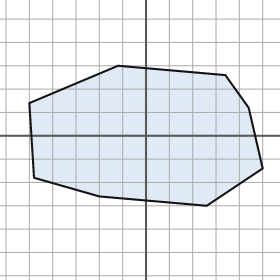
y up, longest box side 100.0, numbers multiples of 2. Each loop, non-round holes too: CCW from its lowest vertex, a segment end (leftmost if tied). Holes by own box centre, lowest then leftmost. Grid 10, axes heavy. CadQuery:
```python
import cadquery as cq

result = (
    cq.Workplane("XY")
    .moveTo(26.0, -30.0)
    .lineTo(50.0, -14.0)
    .lineTo(44.0, 12.0)
    .lineTo(34.0, 26.0)
    .lineTo(-12.0, 30.0)
    .lineTo(-50.0, 14.0)
    .lineTo(-48.0, -18.0)
    .lineTo(-20.0, -26.0)
    .close()
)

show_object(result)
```